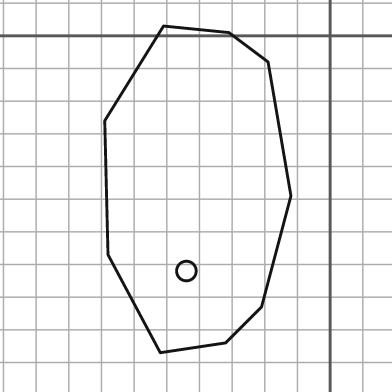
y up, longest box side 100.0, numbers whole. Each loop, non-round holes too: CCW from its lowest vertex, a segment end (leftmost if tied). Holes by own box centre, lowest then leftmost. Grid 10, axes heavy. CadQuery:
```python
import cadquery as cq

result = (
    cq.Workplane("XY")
    .moveTo(-52.0, -97.0)
    .lineTo(-32.0, -94.0)
    .lineTo(-21.0, -83.0)
    .lineTo(-12.0, -49.0)
    .lineTo(-19.0, -8.0)
    .lineTo(-31.0, 1.0)
    .lineTo(-51.0, 3.0)
    .lineTo(-69.0, -26.0)
    .lineTo(-68.0, -67.0)
    .close()
    .moveTo(-44.0, -72.0)
    .circle(3.0)
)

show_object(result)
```